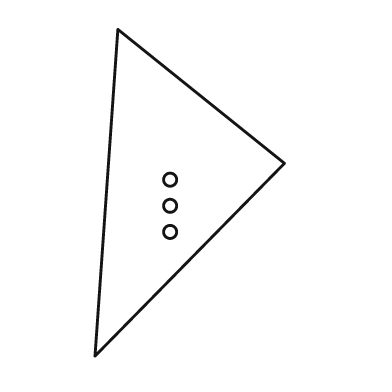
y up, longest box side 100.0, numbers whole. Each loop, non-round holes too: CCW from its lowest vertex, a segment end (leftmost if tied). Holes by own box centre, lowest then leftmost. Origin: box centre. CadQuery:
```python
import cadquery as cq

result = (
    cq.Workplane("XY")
    .moveTo(-29.0, -50.0)
    .lineTo(29.0, 9.0)
    .lineTo(-22.0, 50.0)
    .close()
    .moveTo(-6.0, -12.0)
    .circle(2.0)
    .moveTo(-6.0, -4.0)
    .circle(2.0)
    .moveTo(-6.0, 4.0)
    .circle(2.0)
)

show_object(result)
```